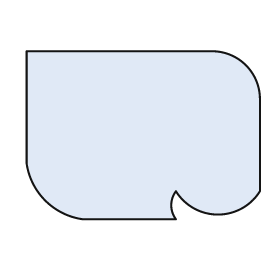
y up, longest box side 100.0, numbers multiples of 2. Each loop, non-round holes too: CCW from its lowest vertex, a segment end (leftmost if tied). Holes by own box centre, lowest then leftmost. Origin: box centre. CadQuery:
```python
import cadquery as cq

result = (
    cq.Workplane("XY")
    .moveTo(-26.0, -36.0)
    .lineTo(14.0, -36.0)
    .threePointArc((12.0, -30.0), (14.0, -24.0))
    .threePointArc((32.0, -34.0), (50.0, -24.0))
    .lineTo(50.0, 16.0)
    .threePointArc((44.0, 30.0), (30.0, 36.0))
    .lineTo(-50.0, 36.0)
    .lineTo(-50.0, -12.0)
    .threePointArc((-42.0, -28.0), (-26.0, -36.0))
    .close()
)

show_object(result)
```